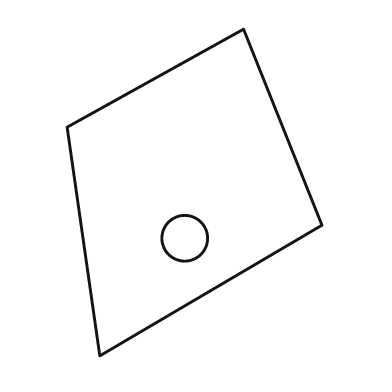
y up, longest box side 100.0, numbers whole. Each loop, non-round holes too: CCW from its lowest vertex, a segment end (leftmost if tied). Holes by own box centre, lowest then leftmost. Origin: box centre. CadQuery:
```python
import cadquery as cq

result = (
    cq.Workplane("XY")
    .moveTo(-29.0, -50.0)
    .lineTo(39.0, -10.0)
    .lineTo(15.0, 50.0)
    .lineTo(-39.0, 20.0)
    .close()
    .moveTo(-3.0, -14.0)
    .circle(7.0)
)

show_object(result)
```